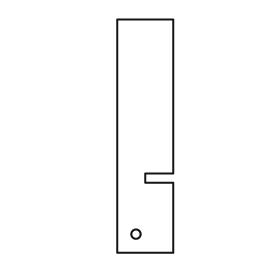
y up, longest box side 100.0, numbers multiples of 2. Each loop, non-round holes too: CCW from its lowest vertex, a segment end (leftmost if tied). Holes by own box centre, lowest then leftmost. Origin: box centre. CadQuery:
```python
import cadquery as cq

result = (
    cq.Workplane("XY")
    .moveTo(-12.0, -50.0)
    .lineTo(12.0, -50.0)
    .lineTo(12.0, -20.0)
    .lineTo(0.0, -20.0)
    .lineTo(0.0, -16.0)
    .lineTo(12.0, -16.0)
    .lineTo(12.0, 50.0)
    .lineTo(-12.0, 50.0)
    .close()
    .moveTo(-4.0, -42.0)
    .circle(2.0)
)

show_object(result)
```